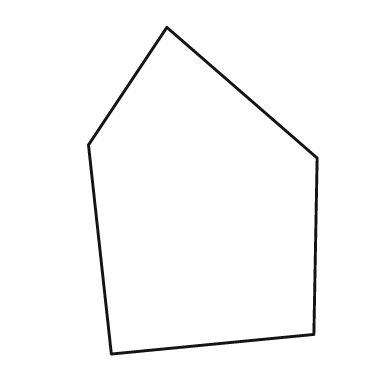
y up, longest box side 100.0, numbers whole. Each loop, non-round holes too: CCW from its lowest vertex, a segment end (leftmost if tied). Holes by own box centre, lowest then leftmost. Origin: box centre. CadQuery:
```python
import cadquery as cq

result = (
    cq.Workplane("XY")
    .moveTo(-28.0, -50.0)
    .lineTo(34.0, -44.0)
    .lineTo(35.0, 10.0)
    .lineTo(-11.0, 50.0)
    .lineTo(-35.0, 14.0)
    .close()
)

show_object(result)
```